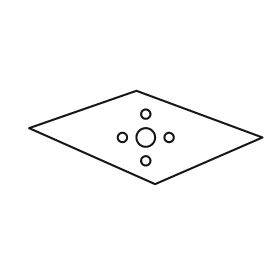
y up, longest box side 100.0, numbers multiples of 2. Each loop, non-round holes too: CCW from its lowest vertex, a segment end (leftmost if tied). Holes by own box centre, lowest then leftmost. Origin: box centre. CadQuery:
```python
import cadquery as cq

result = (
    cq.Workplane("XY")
    .moveTo(4.0, -20.0)
    .lineTo(50.0, 0.0)
    .lineTo(-4.0, 20.0)
    .lineTo(-50.0, 4.0)
    .close()
    .moveTo(0.0, -10.0)
    .circle(2.0)
    .moveTo(-10.0, 0.0)
    .circle(2.0)
    .moveTo(0.0, 0.0)
    .circle(4.0)
    .moveTo(10.0, 0.0)
    .circle(2.0)
    .moveTo(0.0, 10.0)
    .circle(2.0)
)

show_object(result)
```